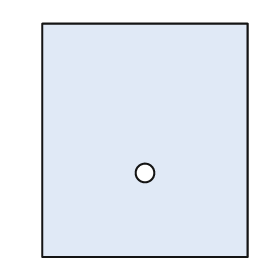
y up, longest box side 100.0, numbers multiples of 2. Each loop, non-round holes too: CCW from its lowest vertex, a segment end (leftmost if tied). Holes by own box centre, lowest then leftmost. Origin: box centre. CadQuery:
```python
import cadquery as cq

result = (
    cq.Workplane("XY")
    .moveTo(-44.0, -50.0)
    .lineTo(44.0, -50.0)
    .lineTo(44.0, 50.0)
    .lineTo(-44.0, 50.0)
    .close()
    .moveTo(0.0, -14.0)
    .circle(4.0)
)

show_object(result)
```